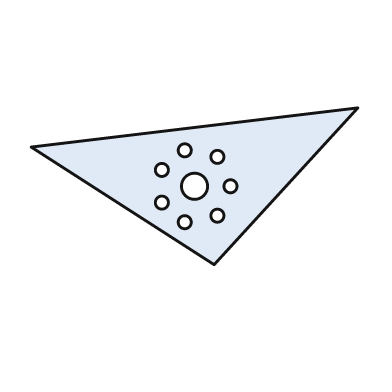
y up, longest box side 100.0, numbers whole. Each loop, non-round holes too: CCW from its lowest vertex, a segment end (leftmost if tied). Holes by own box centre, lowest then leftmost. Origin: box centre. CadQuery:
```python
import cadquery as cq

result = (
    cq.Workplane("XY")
    .moveTo(6.0, -24.0)
    .lineTo(50.0, 24.0)
    .lineTo(-50.0, 12.0)
    .close()
    .moveTo(-3.0, -11.0)
    .circle(2.0)
    .moveTo(7.0, -9.0)
    .circle(2.0)
    .moveTo(-10.0, -5.0)
    .circle(2.0)
    .moveTo(0.0, 0.0)
    .circle(4.0)
    .moveTo(11.0, 0.0)
    .circle(2.0)
    .moveTo(-10.0, 5.0)
    .circle(2.0)
    .moveTo(7.0, 9.0)
    .circle(2.0)
    .moveTo(-3.0, 11.0)
    .circle(2.0)
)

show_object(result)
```